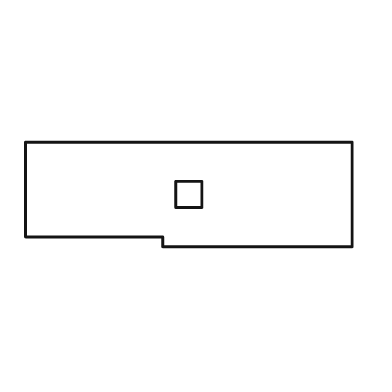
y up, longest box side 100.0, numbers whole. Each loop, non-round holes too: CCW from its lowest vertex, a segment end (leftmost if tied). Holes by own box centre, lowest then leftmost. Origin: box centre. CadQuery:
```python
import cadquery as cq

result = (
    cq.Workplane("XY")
    .moveTo(-8.0, -16.0)
    .lineTo(50.0, -16.0)
    .lineTo(50.0, 16.0)
    .lineTo(-50.0, 16.0)
    .lineTo(-50.0, -13.0)
    .lineTo(-8.0, -13.0)
    .close()
    .moveTo(-4.0, -4.0)
    .lineTo(4.0, -4.0)
    .lineTo(4.0, 4.0)
    .lineTo(-4.0, 4.0)
    .close()
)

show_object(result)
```